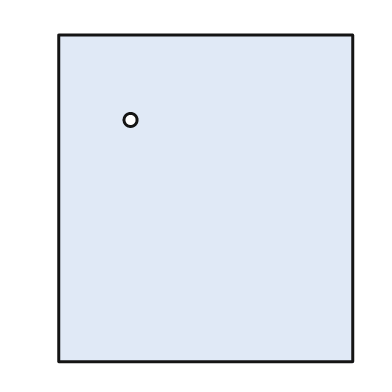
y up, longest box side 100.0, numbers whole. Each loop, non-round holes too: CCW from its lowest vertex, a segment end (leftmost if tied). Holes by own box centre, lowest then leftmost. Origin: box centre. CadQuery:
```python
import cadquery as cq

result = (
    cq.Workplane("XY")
    .moveTo(-45.0, -50.0)
    .lineTo(45.0, -50.0)
    .lineTo(45.0, 50.0)
    .lineTo(-45.0, 50.0)
    .close()
    .moveTo(-23.0, 24.0)
    .circle(2.0)
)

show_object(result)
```